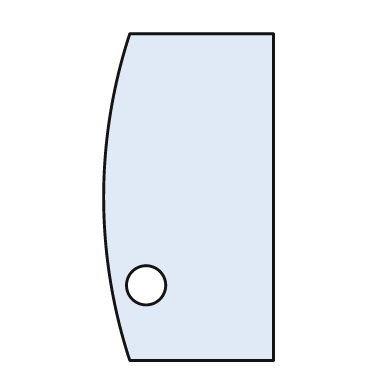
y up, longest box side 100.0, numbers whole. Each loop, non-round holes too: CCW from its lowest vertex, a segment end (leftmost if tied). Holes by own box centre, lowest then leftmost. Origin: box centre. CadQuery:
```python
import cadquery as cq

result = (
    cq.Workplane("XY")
    .moveTo(-18.0, -50.0)
    .lineTo(26.0, -50.0)
    .lineTo(26.0, 50.0)
    .lineTo(-18.0, 50.0)
    .threePointArc((-26.0, 0.0), (-18.0, -50.0))
    .close()
    .moveTo(-13.0, -27.0)
    .circle(6.0)
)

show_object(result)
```